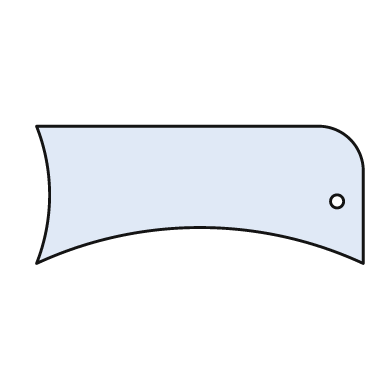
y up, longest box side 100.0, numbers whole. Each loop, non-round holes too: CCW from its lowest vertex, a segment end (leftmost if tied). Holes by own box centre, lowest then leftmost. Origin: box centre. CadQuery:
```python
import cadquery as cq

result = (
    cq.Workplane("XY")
    .moveTo(-50.0, -21.0)
    .threePointArc((0.0, -10.0), (50.0, -21.0))
    .lineTo(50.0, 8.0)
    .threePointArc((46.0, 17.0), (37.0, 21.0))
    .lineTo(-50.0, 21.0)
    .threePointArc((-46.0, 0.0), (-50.0, -21.0))
    .close()
    .moveTo(42.0, -2.0)
    .circle(2.0)
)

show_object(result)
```